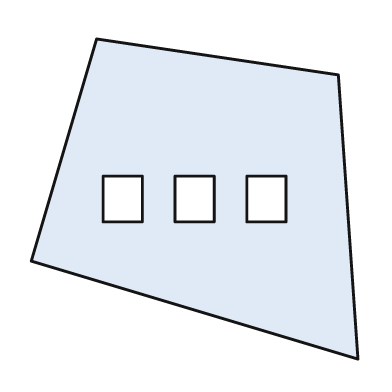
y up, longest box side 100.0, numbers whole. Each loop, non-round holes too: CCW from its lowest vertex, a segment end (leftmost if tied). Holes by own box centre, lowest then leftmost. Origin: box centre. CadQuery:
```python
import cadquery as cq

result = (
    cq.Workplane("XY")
    .moveTo(50.0, -49.0)
    .lineTo(44.0, 38.0)
    .lineTo(-30.0, 49.0)
    .lineTo(-50.0, -19.0)
    .close()
    .moveTo(-28.0, -7.0)
    .lineTo(-16.0, -7.0)
    .lineTo(-16.0, 7.0)
    .lineTo(-28.0, 7.0)
    .close()
    .moveTo(-6.0, -7.0)
    .lineTo(6.0, -7.0)
    .lineTo(6.0, 7.0)
    .lineTo(-6.0, 7.0)
    .close()
    .moveTo(16.0, -7.0)
    .lineTo(28.0, -7.0)
    .lineTo(28.0, 7.0)
    .lineTo(16.0, 7.0)
    .close()
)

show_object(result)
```